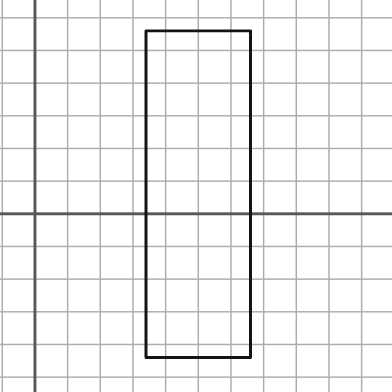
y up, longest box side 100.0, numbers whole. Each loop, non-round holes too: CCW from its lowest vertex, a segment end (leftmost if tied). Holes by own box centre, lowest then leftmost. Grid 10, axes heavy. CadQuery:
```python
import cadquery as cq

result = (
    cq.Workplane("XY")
    .moveTo(34.0, -44.0)
    .lineTo(66.0, -44.0)
    .lineTo(66.0, 56.0)
    .lineTo(34.0, 56.0)
    .close()
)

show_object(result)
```